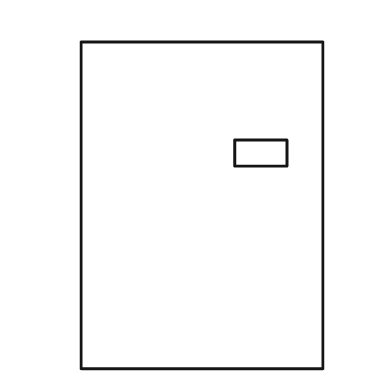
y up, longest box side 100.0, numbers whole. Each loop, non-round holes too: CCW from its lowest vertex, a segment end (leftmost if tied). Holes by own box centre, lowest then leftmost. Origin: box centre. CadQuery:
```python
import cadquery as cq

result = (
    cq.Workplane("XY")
    .moveTo(-37.0, -50.0)
    .lineTo(37.0, -50.0)
    .lineTo(37.0, 50.0)
    .lineTo(-37.0, 50.0)
    .close()
    .moveTo(10.0, 12.0)
    .lineTo(26.0, 12.0)
    .lineTo(26.0, 20.0)
    .lineTo(10.0, 20.0)
    .close()
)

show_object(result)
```